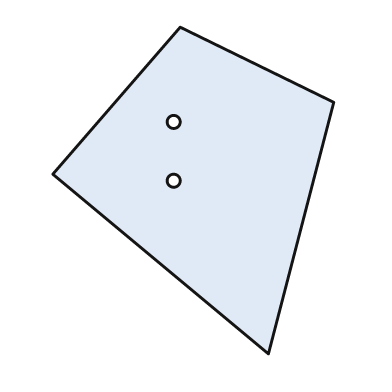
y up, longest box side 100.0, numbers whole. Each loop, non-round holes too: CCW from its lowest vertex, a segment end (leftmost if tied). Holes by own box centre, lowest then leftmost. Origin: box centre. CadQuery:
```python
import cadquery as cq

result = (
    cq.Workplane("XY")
    .moveTo(23.0, -50.0)
    .lineTo(43.0, 27.0)
    .lineTo(-4.0, 50.0)
    .lineTo(-43.0, 5.0)
    .close()
    .moveTo(-6.0, 3.0)
    .circle(2.0)
    .moveTo(-6.0, 21.0)
    .circle(2.0)
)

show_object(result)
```